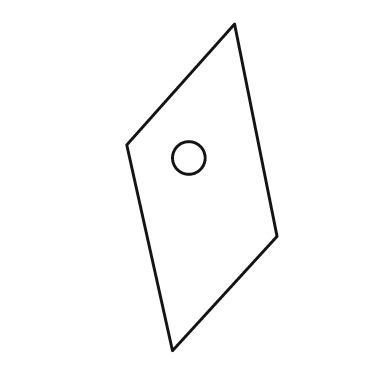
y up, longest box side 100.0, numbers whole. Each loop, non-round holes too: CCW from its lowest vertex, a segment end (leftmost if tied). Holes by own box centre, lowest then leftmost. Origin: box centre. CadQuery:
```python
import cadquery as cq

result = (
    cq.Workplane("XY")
    .moveTo(-9.0, -50.0)
    .lineTo(23.0, -15.0)
    .lineTo(10.0, 50.0)
    .lineTo(-23.0, 13.0)
    .close()
    .moveTo(-4.0, 9.0)
    .circle(5.0)
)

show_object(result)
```